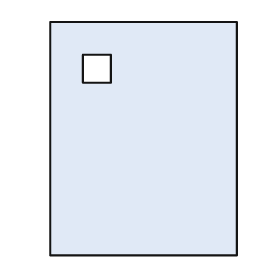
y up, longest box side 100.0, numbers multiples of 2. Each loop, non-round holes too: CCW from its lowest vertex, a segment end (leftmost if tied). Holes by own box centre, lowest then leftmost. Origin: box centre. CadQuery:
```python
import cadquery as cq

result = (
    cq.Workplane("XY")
    .moveTo(-40.0, -50.0)
    .lineTo(40.0, -50.0)
    .lineTo(40.0, 50.0)
    .lineTo(-40.0, 50.0)
    .close()
    .moveTo(-26.0, 24.0)
    .lineTo(-14.0, 24.0)
    .lineTo(-14.0, 36.0)
    .lineTo(-26.0, 36.0)
    .close()
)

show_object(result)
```